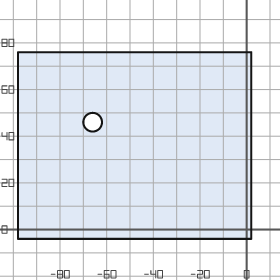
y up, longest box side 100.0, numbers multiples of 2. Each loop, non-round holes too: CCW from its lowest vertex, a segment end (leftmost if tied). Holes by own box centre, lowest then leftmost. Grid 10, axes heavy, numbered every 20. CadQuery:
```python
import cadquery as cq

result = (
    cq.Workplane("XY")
    .moveTo(-98.0, -4.0)
    .lineTo(2.0, -4.0)
    .lineTo(2.0, 76.0)
    .lineTo(-98.0, 76.0)
    .close()
    .moveTo(-66.0, 46.0)
    .circle(4.0)
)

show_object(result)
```